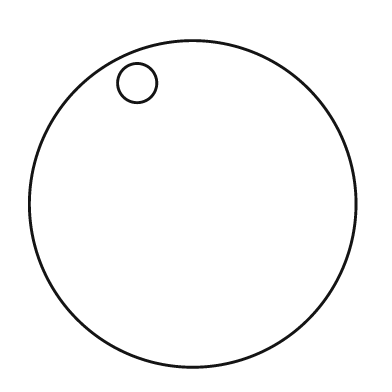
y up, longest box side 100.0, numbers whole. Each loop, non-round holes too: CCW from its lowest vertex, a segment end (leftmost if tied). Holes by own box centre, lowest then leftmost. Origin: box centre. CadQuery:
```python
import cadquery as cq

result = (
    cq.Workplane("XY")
    .moveTo(0.0, 0.0)
    .circle(50.0)
    .moveTo(-17.0, 37.0)
    .circle(6.0)
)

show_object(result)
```